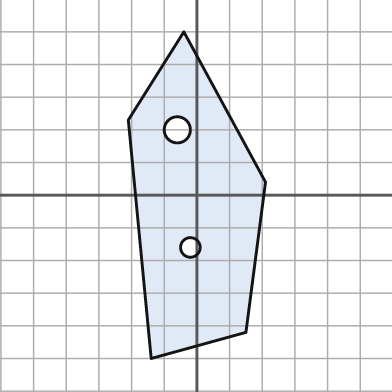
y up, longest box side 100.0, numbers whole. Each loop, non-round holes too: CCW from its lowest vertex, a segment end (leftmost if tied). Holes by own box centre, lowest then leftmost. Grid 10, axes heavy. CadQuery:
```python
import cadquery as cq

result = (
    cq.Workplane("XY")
    .moveTo(-14.0, -50.0)
    .lineTo(15.0, -42.0)
    .lineTo(21.0, 4.0)
    .lineTo(-4.0, 50.0)
    .lineTo(-21.0, 23.0)
    .close()
    .moveTo(-2.0, -16.0)
    .circle(3.0)
    .moveTo(-6.0, 20.0)
    .circle(4.0)
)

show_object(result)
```